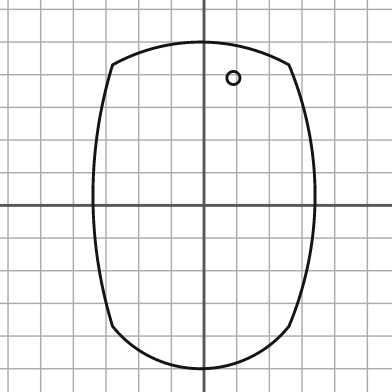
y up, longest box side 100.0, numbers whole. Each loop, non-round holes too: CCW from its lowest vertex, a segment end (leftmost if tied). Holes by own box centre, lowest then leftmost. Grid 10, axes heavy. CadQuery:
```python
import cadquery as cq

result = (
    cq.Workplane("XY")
    .moveTo(-28.0, -37.0)
    .threePointArc((-1.0, -50.0), (26.0, -37.0))
    .threePointArc((34.0, 3.0), (26.0, 43.0))
    .threePointArc((-1.0, 50.0), (-28.0, 43.0))
    .threePointArc((-34.0, 3.0), (-28.0, -37.0))
    .close()
    .moveTo(9.0, 39.0)
    .circle(2.0)
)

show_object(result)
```